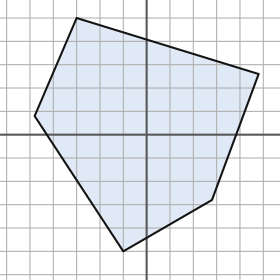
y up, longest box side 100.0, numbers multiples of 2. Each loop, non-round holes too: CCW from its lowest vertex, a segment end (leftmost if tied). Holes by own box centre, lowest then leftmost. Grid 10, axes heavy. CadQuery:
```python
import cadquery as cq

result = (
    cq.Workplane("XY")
    .moveTo(-10.0, -50.0)
    .lineTo(28.0, -28.0)
    .lineTo(48.0, 26.0)
    .lineTo(-30.0, 50.0)
    .lineTo(-48.0, 8.0)
    .close()
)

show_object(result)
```